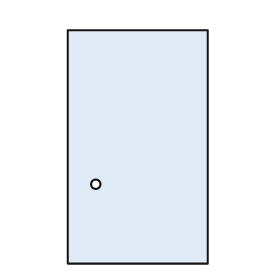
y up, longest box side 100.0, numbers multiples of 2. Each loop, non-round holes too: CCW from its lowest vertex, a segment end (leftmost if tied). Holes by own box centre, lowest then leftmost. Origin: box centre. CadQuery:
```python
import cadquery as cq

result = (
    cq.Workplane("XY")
    .moveTo(-30.0, -50.0)
    .lineTo(30.0, -50.0)
    .lineTo(30.0, 50.0)
    .lineTo(-30.0, 50.0)
    .close()
    .moveTo(-18.0, -16.0)
    .circle(2.0)
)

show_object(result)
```